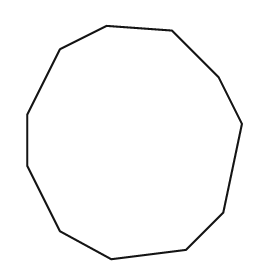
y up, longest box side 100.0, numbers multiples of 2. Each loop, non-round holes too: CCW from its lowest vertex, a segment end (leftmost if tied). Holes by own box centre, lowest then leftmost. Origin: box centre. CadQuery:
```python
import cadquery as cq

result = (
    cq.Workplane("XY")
    .moveTo(-10.0, -50.0)
    .lineTo(22.0, -46.0)
    .lineTo(38.0, -30.0)
    .lineTo(46.0, 8.0)
    .lineTo(36.0, 28.0)
    .lineTo(16.0, 48.0)
    .lineTo(-12.0, 50.0)
    .lineTo(-32.0, 40.0)
    .lineTo(-46.0, 12.0)
    .lineTo(-46.0, -10.0)
    .lineTo(-32.0, -38.0)
    .close()
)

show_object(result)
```